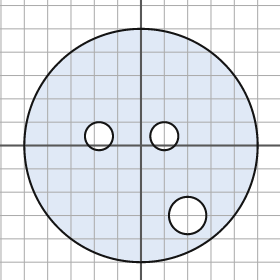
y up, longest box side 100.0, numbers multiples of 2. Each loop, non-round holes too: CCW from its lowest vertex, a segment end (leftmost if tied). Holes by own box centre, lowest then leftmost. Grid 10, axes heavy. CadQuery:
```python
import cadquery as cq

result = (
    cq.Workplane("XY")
    .moveTo(0.0, 0.0)
    .circle(50.0)
    .moveTo(20.0, -30.0)
    .circle(8.0)
    .moveTo(-18.0, 4.0)
    .circle(6.0)
    .moveTo(10.0, 4.0)
    .circle(6.0)
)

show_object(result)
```